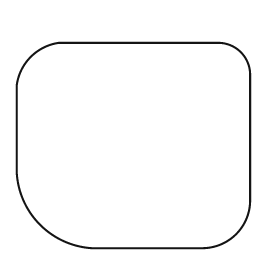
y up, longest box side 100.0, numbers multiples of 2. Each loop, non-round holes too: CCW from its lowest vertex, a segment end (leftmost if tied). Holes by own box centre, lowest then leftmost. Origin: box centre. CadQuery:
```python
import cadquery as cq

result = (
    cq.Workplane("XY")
    .moveTo(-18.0, -44.0)
    .lineTo(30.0, -44.0)
    .threePointArc((44.0, -38.0), (50.0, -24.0))
    .lineTo(50.0, 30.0)
    .threePointArc((46.0, 40.0), (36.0, 44.0))
    .lineTo(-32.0, 44.0)
    .threePointArc((-44.0, 38.0), (-50.0, 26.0))
    .lineTo(-50.0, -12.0)
    .threePointArc((-40.0, -34.0), (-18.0, -44.0))
    .close()
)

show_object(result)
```